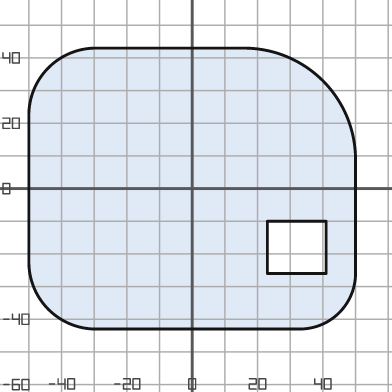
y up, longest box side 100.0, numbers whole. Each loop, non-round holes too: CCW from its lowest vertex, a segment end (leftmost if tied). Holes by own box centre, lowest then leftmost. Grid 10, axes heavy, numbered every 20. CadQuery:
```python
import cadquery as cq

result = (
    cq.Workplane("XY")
    .moveTo(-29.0, -43.0)
    .lineTo(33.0, -43.0)
    .threePointArc((45.0, -38.0), (50.0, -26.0))
    .lineTo(50.0, 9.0)
    .threePointArc((40.0, 33.0), (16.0, 43.0))
    .lineTo(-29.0, 43.0)
    .threePointArc((-44.0, 37.0), (-50.0, 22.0))
    .lineTo(-50.0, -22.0)
    .threePointArc((-44.0, -37.0), (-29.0, -43.0))
    .close()
    .moveTo(23.0, -26.0)
    .lineTo(41.0, -26.0)
    .lineTo(41.0, -10.0)
    .lineTo(23.0, -10.0)
    .close()
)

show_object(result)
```